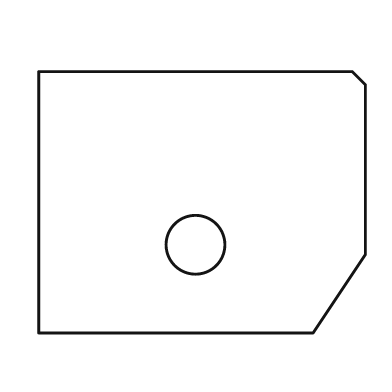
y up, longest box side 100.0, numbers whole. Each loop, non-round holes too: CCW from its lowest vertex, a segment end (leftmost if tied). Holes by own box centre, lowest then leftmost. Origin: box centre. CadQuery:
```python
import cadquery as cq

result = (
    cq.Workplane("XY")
    .moveTo(-50.0, -40.0)
    .lineTo(34.0, -40.0)
    .lineTo(50.0, -16.0)
    .lineTo(50.0, 36.0)
    .lineTo(46.0, 40.0)
    .lineTo(-50.0, 40.0)
    .close()
    .moveTo(-2.0, -13.0)
    .circle(9.0)
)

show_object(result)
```